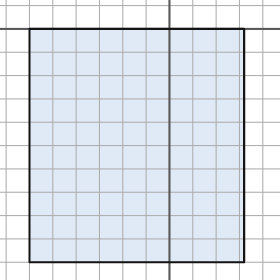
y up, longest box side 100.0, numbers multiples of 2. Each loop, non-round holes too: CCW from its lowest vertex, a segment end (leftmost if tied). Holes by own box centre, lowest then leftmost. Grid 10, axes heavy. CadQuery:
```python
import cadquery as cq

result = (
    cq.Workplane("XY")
    .moveTo(-60.0, -100.0)
    .lineTo(32.0, -100.0)
    .lineTo(32.0, 0.0)
    .lineTo(-60.0, 0.0)
    .close()
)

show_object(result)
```